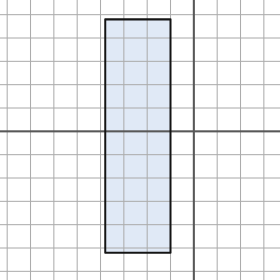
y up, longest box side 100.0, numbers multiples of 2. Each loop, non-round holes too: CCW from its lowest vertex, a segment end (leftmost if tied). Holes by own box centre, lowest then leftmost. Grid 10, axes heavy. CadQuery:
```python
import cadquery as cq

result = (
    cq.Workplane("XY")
    .moveTo(-38.0, -52.0)
    .lineTo(-10.0, -52.0)
    .lineTo(-10.0, 48.0)
    .lineTo(-38.0, 48.0)
    .close()
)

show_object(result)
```